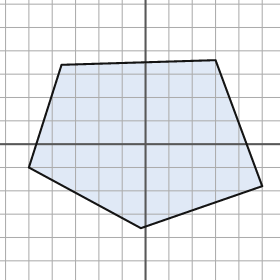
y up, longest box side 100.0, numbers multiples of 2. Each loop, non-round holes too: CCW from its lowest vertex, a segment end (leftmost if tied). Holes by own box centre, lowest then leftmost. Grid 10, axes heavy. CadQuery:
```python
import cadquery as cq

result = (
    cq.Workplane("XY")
    .moveTo(-2.0, -36.0)
    .lineTo(50.0, -18.0)
    .lineTo(30.0, 36.0)
    .lineTo(-36.0, 34.0)
    .lineTo(-50.0, -10.0)
    .close()
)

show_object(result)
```